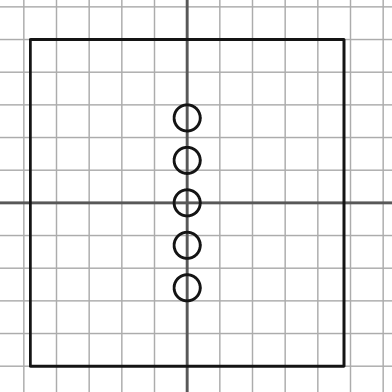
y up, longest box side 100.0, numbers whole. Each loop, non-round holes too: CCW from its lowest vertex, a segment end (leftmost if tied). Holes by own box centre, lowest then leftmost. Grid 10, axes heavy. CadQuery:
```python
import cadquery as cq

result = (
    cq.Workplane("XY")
    .moveTo(-48.0, -50.0)
    .lineTo(48.0, -50.0)
    .lineTo(48.0, 50.0)
    .lineTo(-48.0, 50.0)
    .close()
    .moveTo(0.0, -26.0)
    .circle(4.0)
    .moveTo(0.0, -13.0)
    .circle(4.0)
    .moveTo(0.0, 0.0)
    .circle(4.0)
    .moveTo(0.0, 13.0)
    .circle(4.0)
    .moveTo(0.0, 26.0)
    .circle(4.0)
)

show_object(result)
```